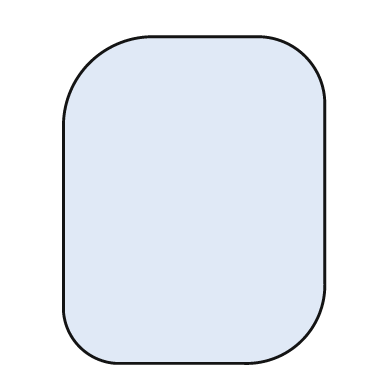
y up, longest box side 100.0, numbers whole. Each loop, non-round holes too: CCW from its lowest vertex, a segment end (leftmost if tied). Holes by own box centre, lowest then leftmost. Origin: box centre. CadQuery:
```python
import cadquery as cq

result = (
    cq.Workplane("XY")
    .moveTo(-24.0, -50.0)
    .lineTo(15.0, -50.0)
    .threePointArc((33.0, -43.0), (40.0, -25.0))
    .lineTo(40.0, 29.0)
    .threePointArc((34.0, 44.0), (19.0, 50.0))
    .lineTo(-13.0, 50.0)
    .threePointArc((-32.0, 42.0), (-40.0, 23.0))
    .lineTo(-40.0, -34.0)
    .threePointArc((-35.0, -45.0), (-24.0, -50.0))
    .close()
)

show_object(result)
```